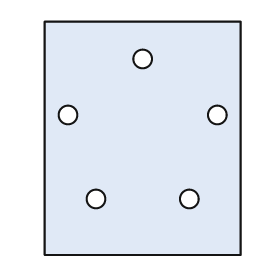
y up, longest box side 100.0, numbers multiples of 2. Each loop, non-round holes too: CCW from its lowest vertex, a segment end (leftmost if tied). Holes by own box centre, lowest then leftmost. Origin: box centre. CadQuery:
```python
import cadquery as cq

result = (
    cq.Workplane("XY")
    .moveTo(-42.0, -50.0)
    .lineTo(42.0, -50.0)
    .lineTo(42.0, 50.0)
    .lineTo(-42.0, 50.0)
    .close()
    .moveTo(-20.0, -26.0)
    .circle(4.0)
    .moveTo(20.0, -26.0)
    .circle(4.0)
    .moveTo(-32.0, 10.0)
    .circle(4.0)
    .moveTo(32.0, 10.0)
    .circle(4.0)
    .moveTo(0.0, 34.0)
    .circle(4.0)
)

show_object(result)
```